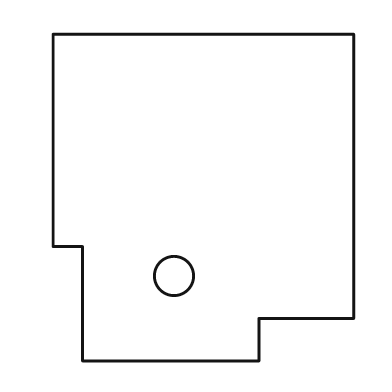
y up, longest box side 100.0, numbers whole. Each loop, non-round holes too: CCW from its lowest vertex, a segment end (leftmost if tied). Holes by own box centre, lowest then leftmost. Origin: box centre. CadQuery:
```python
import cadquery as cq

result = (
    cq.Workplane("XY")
    .moveTo(-37.0, -50.0)
    .lineTo(17.0, -50.0)
    .lineTo(17.0, -37.0)
    .lineTo(46.0, -37.0)
    .lineTo(46.0, 50.0)
    .lineTo(-46.0, 50.0)
    .lineTo(-46.0, -15.0)
    .lineTo(-37.0, -15.0)
    .close()
    .moveTo(-9.0, -24.0)
    .circle(6.0)
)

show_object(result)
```